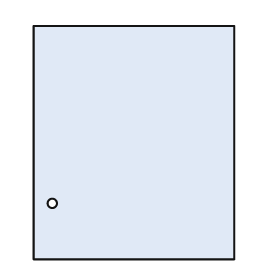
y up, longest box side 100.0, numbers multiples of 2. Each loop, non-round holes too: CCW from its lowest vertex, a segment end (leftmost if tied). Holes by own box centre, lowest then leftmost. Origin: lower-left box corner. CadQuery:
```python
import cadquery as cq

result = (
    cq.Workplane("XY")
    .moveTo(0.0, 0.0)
    .lineTo(86.0, 0.0)
    .lineTo(86.0, 100.0)
    .lineTo(0.0, 100.0)
    .close()
    .moveTo(8.0, 24.0)
    .circle(2.0)
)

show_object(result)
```